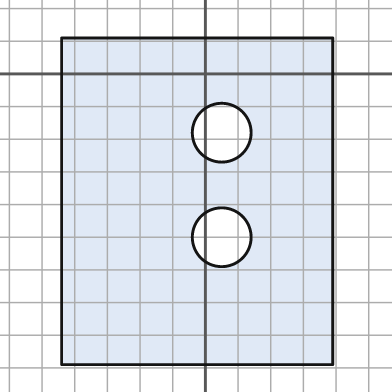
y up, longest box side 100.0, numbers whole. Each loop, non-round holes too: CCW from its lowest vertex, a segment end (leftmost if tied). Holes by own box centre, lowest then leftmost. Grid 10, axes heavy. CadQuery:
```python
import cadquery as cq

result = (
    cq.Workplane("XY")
    .moveTo(-44.0, -89.0)
    .lineTo(39.0, -89.0)
    .lineTo(39.0, 11.0)
    .lineTo(-44.0, 11.0)
    .close()
    .moveTo(5.0, -50.0)
    .circle(9.0)
    .moveTo(5.0, -18.0)
    .circle(9.0)
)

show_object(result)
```